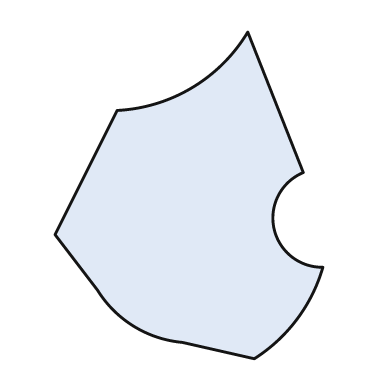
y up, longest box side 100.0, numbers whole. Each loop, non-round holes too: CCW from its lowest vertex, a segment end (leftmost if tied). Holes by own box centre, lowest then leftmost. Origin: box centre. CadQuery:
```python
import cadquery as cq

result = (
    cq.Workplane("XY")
    .moveTo(20.0, -50.0)
    .threePointArc((33.0, -38.0), (41.0, -22.0))
    .threePointArc((26.0, -10.0), (35.0, 7.0))
    .lineTo(18.0, 50.0)
    .threePointArc((1.0, 33.0), (-22.0, 26.0))
    .lineTo(-41.0, -12.0)
    .lineTo(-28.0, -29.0)
    .threePointArc((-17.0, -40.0), (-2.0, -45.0))
    .close()
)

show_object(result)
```